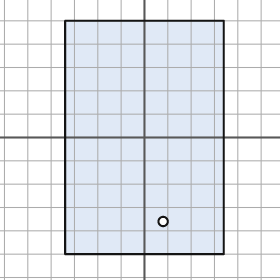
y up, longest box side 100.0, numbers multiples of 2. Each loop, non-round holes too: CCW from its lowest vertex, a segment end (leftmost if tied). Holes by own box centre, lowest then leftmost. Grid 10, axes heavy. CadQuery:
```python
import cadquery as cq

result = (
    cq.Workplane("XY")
    .moveTo(-34.0, -50.0)
    .lineTo(34.0, -50.0)
    .lineTo(34.0, 50.0)
    .lineTo(-34.0, 50.0)
    .close()
    .moveTo(8.0, -36.0)
    .circle(2.0)
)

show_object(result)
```